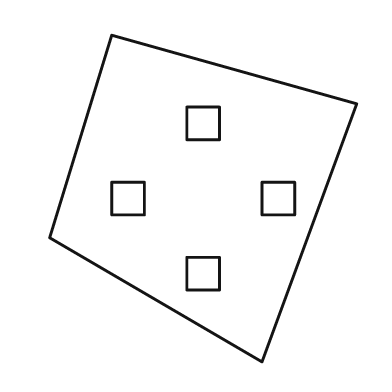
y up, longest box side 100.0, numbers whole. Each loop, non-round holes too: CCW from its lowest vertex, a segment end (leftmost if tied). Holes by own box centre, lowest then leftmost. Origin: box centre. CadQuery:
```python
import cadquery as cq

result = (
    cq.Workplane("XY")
    .moveTo(18.0, -50.0)
    .lineTo(47.0, 29.0)
    .lineTo(-28.0, 50.0)
    .lineTo(-47.0, -12.0)
    .close()
    .moveTo(-5.0, -28.0)
    .lineTo(5.0, -28.0)
    .lineTo(5.0, -18.0)
    .lineTo(-5.0, -18.0)
    .close()
    .moveTo(-28.0, -5.0)
    .lineTo(-18.0, -5.0)
    .lineTo(-18.0, 5.0)
    .lineTo(-28.0, 5.0)
    .close()
    .moveTo(18.0, -5.0)
    .lineTo(28.0, -5.0)
    .lineTo(28.0, 5.0)
    .lineTo(18.0, 5.0)
    .close()
    .moveTo(-5.0, 18.0)
    .lineTo(5.0, 18.0)
    .lineTo(5.0, 28.0)
    .lineTo(-5.0, 28.0)
    .close()
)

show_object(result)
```